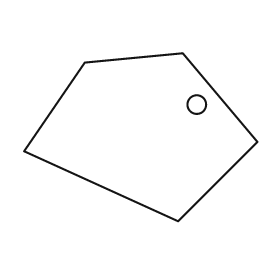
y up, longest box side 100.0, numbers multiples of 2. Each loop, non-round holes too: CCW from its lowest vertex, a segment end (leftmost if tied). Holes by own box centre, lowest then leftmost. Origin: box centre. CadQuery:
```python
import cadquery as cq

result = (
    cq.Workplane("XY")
    .moveTo(16.0, -36.0)
    .lineTo(50.0, -2.0)
    .lineTo(18.0, 36.0)
    .lineTo(-24.0, 32.0)
    .lineTo(-50.0, -6.0)
    .close()
    .moveTo(24.0, 14.0)
    .circle(4.0)
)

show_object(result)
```